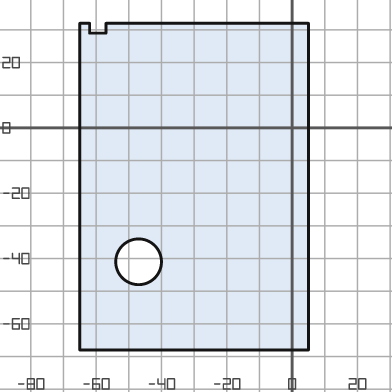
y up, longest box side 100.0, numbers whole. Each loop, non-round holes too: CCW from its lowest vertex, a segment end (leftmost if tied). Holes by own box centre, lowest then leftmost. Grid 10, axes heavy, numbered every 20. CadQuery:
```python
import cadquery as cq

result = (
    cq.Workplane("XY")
    .moveTo(-65.0, -68.0)
    .lineTo(5.0, -68.0)
    .lineTo(5.0, 32.0)
    .lineTo(-57.0, 32.0)
    .lineTo(-57.0, 29.0)
    .lineTo(-62.0, 29.0)
    .lineTo(-62.0, 32.0)
    .lineTo(-65.0, 32.0)
    .close()
    .moveTo(-47.0, -41.0)
    .circle(7.0)
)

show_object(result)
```